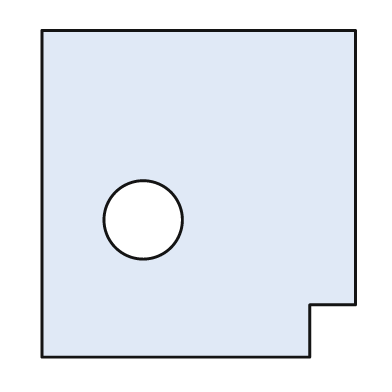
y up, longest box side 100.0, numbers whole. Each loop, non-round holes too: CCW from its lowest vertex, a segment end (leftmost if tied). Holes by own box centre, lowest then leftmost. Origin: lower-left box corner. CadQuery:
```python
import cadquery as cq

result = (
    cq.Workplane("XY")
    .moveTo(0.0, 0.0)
    .lineTo(82.0, 0.0)
    .lineTo(82.0, 16.0)
    .lineTo(96.0, 16.0)
    .lineTo(96.0, 100.0)
    .lineTo(0.0, 100.0)
    .close()
    .moveTo(31.0, 42.0)
    .circle(12.0)
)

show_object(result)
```